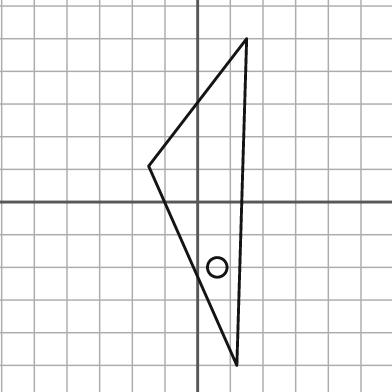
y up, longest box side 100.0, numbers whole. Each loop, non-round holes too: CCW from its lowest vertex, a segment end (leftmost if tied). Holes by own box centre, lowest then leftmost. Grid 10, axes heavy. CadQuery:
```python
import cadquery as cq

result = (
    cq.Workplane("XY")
    .moveTo(12.0, -50.0)
    .lineTo(15.0, 50.0)
    .lineTo(-15.0, 11.0)
    .close()
    .moveTo(6.0, -20.0)
    .circle(3.0)
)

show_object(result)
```